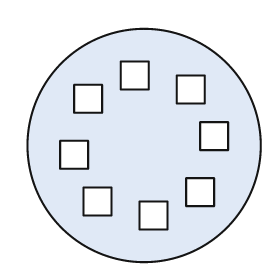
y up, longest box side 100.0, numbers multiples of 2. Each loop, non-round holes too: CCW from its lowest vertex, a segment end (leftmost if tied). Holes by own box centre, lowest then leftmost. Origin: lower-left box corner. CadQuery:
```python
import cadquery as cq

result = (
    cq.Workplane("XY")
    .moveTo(50.0, 50.0)
    .circle(50.0)
    .moveTo(48.0, 14.0)
    .lineTo(60.0, 14.0)
    .lineTo(60.0, 26.0)
    .lineTo(48.0, 26.0)
    .close()
    .moveTo(24.0, 20.0)
    .lineTo(36.0, 20.0)
    .lineTo(36.0, 32.0)
    .lineTo(24.0, 32.0)
    .close()
    .moveTo(68.0, 24.0)
    .lineTo(80.0, 24.0)
    .lineTo(80.0, 36.0)
    .lineTo(68.0, 36.0)
    .close()
    .moveTo(14.0, 40.0)
    .lineTo(26.0, 40.0)
    .lineTo(26.0, 52.0)
    .lineTo(14.0, 52.0)
    .close()
    .moveTo(74.0, 48.0)
    .lineTo(86.0, 48.0)
    .lineTo(86.0, 60.0)
    .lineTo(74.0, 60.0)
    .close()
    .moveTo(20.0, 64.0)
    .lineTo(32.0, 64.0)
    .lineTo(32.0, 76.0)
    .lineTo(20.0, 76.0)
    .close()
    .moveTo(64.0, 68.0)
    .lineTo(76.0, 68.0)
    .lineTo(76.0, 80.0)
    .lineTo(64.0, 80.0)
    .close()
    .moveTo(40.0, 74.0)
    .lineTo(52.0, 74.0)
    .lineTo(52.0, 86.0)
    .lineTo(40.0, 86.0)
    .close()
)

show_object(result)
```